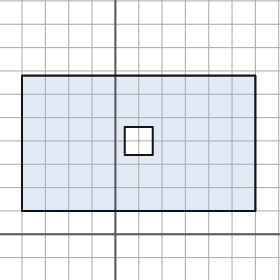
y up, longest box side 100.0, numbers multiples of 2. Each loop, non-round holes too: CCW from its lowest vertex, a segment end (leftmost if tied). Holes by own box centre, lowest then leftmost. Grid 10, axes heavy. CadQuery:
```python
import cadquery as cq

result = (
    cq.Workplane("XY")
    .moveTo(-40.0, 10.0)
    .lineTo(60.0, 10.0)
    .lineTo(60.0, 68.0)
    .lineTo(-40.0, 68.0)
    .close()
    .moveTo(4.0, 34.0)
    .lineTo(16.0, 34.0)
    .lineTo(16.0, 46.0)
    .lineTo(4.0, 46.0)
    .close()
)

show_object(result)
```